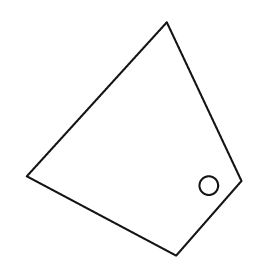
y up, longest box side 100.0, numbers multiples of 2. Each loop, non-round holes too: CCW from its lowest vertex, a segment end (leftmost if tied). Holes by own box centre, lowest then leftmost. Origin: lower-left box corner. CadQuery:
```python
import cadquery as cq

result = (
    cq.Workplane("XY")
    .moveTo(64.0, 0.0)
    .lineTo(92.0, 32.0)
    .lineTo(60.0, 100.0)
    .lineTo(0.0, 34.0)
    .close()
    .moveTo(78.0, 30.0)
    .circle(4.0)
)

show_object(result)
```